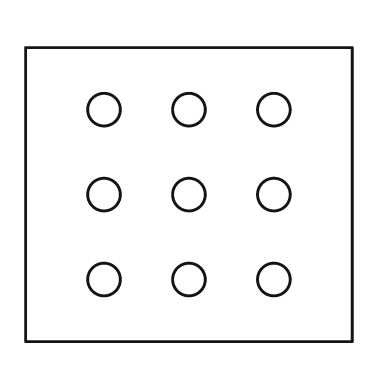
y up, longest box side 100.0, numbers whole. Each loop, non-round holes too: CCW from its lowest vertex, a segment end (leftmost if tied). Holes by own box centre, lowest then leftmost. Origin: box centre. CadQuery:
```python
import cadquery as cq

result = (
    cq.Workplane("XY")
    .moveTo(-50.0, -45.0)
    .lineTo(50.0, -45.0)
    .lineTo(50.0, 45.0)
    .lineTo(-50.0, 45.0)
    .close()
    .moveTo(-26.0, -26.0)
    .circle(5.0)
    .moveTo(0.0, -26.0)
    .circle(5.0)
    .moveTo(26.0, -26.0)
    .circle(5.0)
    .moveTo(-26.0, 0.0)
    .circle(5.0)
    .moveTo(0.0, 0.0)
    .circle(5.0)
    .moveTo(26.0, 0.0)
    .circle(5.0)
    .moveTo(-26.0, 26.0)
    .circle(5.0)
    .moveTo(0.0, 26.0)
    .circle(5.0)
    .moveTo(26.0, 26.0)
    .circle(5.0)
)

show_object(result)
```